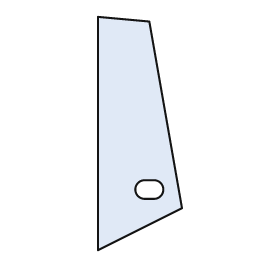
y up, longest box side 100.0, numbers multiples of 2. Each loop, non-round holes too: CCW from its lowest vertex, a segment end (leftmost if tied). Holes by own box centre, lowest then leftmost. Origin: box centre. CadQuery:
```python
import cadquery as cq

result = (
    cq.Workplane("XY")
    .moveTo(-18.0, -50.0)
    .lineTo(18.0, -32.0)
    .lineTo(4.0, 48.0)
    .lineTo(-18.0, 50.0)
    .close()
    .moveTo(2.0, -28.0)
    .lineTo(6.0, -28.0)
    .threePointArc((10.0, -24.0), (6.0, -20.0))
    .lineTo(2.0, -20.0)
    .threePointArc((-2.0, -24.0), (2.0, -28.0))
    .close()
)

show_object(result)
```